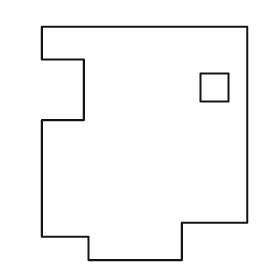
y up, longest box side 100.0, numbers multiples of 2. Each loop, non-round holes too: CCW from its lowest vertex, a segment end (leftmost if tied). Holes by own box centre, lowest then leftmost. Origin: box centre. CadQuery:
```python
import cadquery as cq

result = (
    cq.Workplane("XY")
    .moveTo(-24.0, -50.0)
    .lineTo(16.0, -50.0)
    .lineTo(16.0, -34.0)
    .lineTo(44.0, -34.0)
    .lineTo(44.0, 50.0)
    .lineTo(-44.0, 50.0)
    .lineTo(-44.0, 36.0)
    .lineTo(-26.0, 36.0)
    .lineTo(-26.0, 10.0)
    .lineTo(-44.0, 10.0)
    .lineTo(-44.0, -40.0)
    .lineTo(-24.0, -40.0)
    .close()
    .moveTo(24.0, 18.0)
    .lineTo(36.0, 18.0)
    .lineTo(36.0, 30.0)
    .lineTo(24.0, 30.0)
    .close()
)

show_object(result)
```